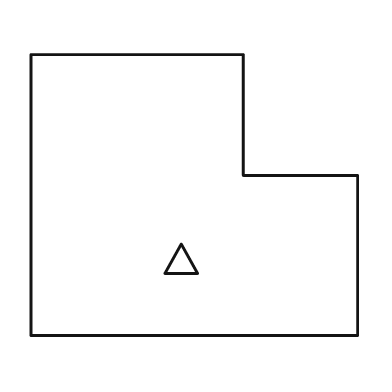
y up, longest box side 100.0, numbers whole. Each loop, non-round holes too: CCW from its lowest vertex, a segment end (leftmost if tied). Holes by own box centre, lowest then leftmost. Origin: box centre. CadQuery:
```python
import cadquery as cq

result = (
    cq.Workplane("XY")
    .moveTo(-50.0, -43.0)
    .lineTo(50.0, -43.0)
    .lineTo(50.0, 6.0)
    .lineTo(15.0, 6.0)
    .lineTo(15.0, 43.0)
    .lineTo(-50.0, 43.0)
    .close()
    .moveTo(-9.0, -24.0)
    .lineTo(1.0, -24.0)
    .lineTo(-4.0, -15.0)
    .close()
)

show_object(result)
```